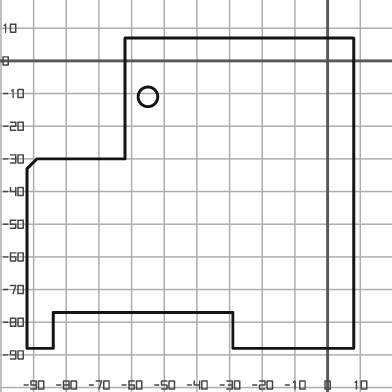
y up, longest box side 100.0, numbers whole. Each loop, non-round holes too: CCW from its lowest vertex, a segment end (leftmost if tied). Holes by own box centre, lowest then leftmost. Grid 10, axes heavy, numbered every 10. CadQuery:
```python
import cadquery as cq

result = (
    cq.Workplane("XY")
    .moveTo(-92.0, -88.0)
    .lineTo(-84.0, -88.0)
    .lineTo(-84.0, -77.0)
    .lineTo(-29.0, -77.0)
    .lineTo(-29.0, -88.0)
    .lineTo(8.0, -88.0)
    .lineTo(8.0, 7.0)
    .lineTo(-62.0, 7.0)
    .lineTo(-62.0, -30.0)
    .lineTo(-89.0, -30.0)
    .lineTo(-92.0, -33.0)
    .close()
    .moveTo(-55.0, -11.0)
    .circle(3.0)
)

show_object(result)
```